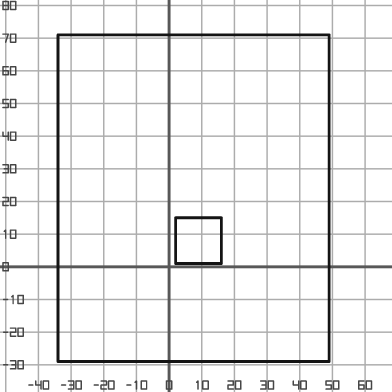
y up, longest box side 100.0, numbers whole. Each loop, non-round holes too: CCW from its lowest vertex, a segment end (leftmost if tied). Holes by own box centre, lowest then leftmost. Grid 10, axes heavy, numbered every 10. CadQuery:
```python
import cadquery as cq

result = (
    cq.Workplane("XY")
    .moveTo(-34.0, -29.0)
    .lineTo(49.0, -29.0)
    .lineTo(49.0, 71.0)
    .lineTo(-34.0, 71.0)
    .close()
    .moveTo(2.0, 1.0)
    .lineTo(16.0, 1.0)
    .lineTo(16.0, 15.0)
    .lineTo(2.0, 15.0)
    .close()
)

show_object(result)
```